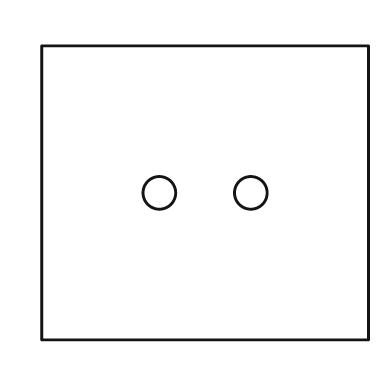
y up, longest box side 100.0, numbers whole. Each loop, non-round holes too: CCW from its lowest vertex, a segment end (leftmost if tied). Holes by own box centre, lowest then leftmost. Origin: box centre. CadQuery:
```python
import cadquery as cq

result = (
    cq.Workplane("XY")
    .moveTo(-50.0, -45.0)
    .lineTo(50.0, -45.0)
    .lineTo(50.0, 45.0)
    .lineTo(-50.0, 45.0)
    .close()
    .moveTo(-14.0, 0.0)
    .circle(5.0)
    .moveTo(14.0, 0.0)
    .circle(5.0)
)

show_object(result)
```